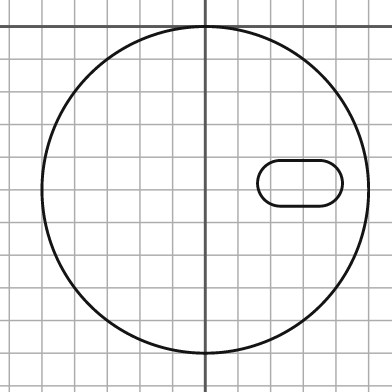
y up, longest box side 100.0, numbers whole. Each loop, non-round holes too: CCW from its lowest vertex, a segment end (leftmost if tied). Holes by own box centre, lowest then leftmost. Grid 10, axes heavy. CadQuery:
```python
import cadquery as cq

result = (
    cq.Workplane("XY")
    .moveTo(0.0, -50.0)
    .circle(50.0)
    .moveTo(23.0, -55.0)
    .lineTo(35.0, -55.0)
    .threePointArc((42.0, -48.0), (35.0, -41.0))
    .lineTo(23.0, -41.0)
    .threePointArc((16.0, -48.0), (23.0, -55.0))
    .close()
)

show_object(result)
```